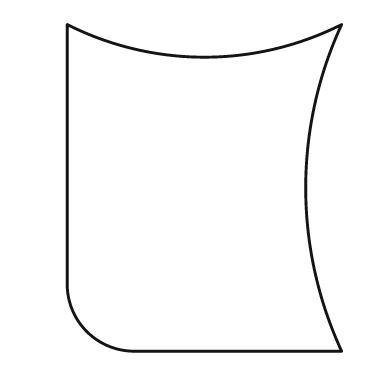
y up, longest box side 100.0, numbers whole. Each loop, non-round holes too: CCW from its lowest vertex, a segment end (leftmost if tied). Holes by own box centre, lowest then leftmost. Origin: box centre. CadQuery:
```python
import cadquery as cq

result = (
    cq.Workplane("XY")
    .moveTo(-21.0, -50.0)
    .lineTo(42.0, -50.0)
    .threePointArc((31.0, 0.0), (42.0, 50.0))
    .threePointArc((0.0, 40.0), (-42.0, 50.0))
    .lineTo(-42.0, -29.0)
    .threePointArc((-36.0, -44.0), (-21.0, -50.0))
    .close()
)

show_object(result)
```